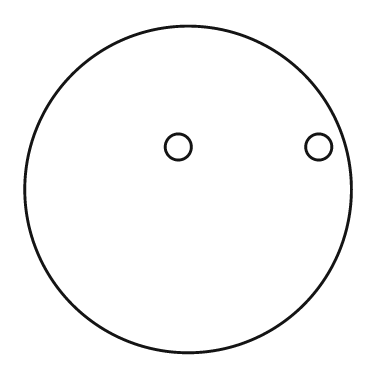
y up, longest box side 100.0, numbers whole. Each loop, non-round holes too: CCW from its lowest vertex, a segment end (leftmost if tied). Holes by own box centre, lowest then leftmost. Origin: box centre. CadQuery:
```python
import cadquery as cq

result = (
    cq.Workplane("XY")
    .moveTo(0.0, 0.0)
    .circle(50.0)
    .moveTo(-3.0, 13.0)
    .circle(4.0)
    .moveTo(40.0, 13.0)
    .circle(4.0)
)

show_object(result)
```